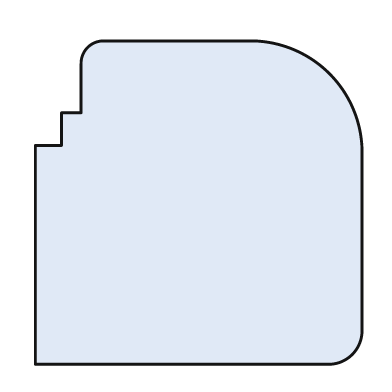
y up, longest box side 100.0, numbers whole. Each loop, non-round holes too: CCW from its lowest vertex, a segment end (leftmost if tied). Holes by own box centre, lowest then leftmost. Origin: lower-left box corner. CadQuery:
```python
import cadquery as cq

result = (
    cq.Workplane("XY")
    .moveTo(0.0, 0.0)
    .lineTo(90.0, 0.0)
    .threePointArc((97.0, 3.0), (100.0, 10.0))
    .lineTo(100.0, 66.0)
    .threePointArc((90.0, 89.0), (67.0, 99.0))
    .lineTo(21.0, 99.0)
    .threePointArc((16.0, 97.0), (14.0, 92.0))
    .lineTo(14.0, 77.0)
    .lineTo(8.0, 77.0)
    .lineTo(8.0, 67.0)
    .lineTo(0.0, 67.0)
    .close()
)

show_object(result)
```